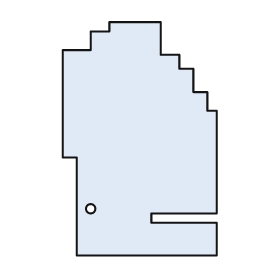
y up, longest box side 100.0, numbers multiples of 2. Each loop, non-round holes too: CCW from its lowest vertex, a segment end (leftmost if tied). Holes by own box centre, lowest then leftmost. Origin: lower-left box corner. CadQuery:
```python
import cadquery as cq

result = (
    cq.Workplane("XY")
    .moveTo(6.0, 0.0)
    .lineTo(66.0, 0.0)
    .lineTo(66.0, 14.0)
    .lineTo(38.0, 14.0)
    .lineTo(38.0, 18.0)
    .lineTo(66.0, 18.0)
    .lineTo(66.0, 62.0)
    .lineTo(62.0, 62.0)
    .lineTo(62.0, 70.0)
    .lineTo(56.0, 70.0)
    .lineTo(56.0, 80.0)
    .lineTo(50.0, 80.0)
    .lineTo(50.0, 86.0)
    .lineTo(42.0, 86.0)
    .lineTo(42.0, 100.0)
    .lineTo(20.0, 100.0)
    .lineTo(20.0, 96.0)
    .lineTo(12.0, 96.0)
    .lineTo(12.0, 88.0)
    .lineTo(0.0, 88.0)
    .lineTo(0.0, 42.0)
    .lineTo(6.0, 42.0)
    .close()
    .moveTo(12.0, 20.0)
    .circle(2.0)
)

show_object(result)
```